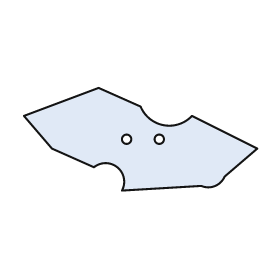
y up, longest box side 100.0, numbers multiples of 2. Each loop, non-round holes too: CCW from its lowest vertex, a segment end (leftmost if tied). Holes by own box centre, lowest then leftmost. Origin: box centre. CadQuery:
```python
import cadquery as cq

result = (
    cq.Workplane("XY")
    .moveTo(-8.0, -22.0)
    .lineTo(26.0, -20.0)
    .threePointArc((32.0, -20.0), (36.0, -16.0))
    .lineTo(50.0, -4.0)
    .lineTo(22.0, 10.0)
    .threePointArc((10.0, 6.0), (0.0, 14.0))
    .lineTo(-18.0, 22.0)
    .lineTo(-50.0, 10.0)
    .lineTo(-38.0, -4.0)
    .lineTo(-20.0, -12.0)
    .threePointArc((-10.0, -12.0), (-8.0, -22.0))
    .close()
    .moveTo(-6.0, 0.0)
    .circle(2.0)
    .moveTo(8.0, 0.0)
    .circle(2.0)
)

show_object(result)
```